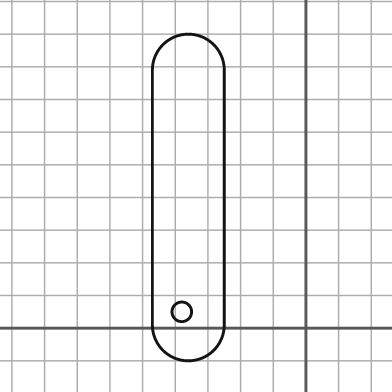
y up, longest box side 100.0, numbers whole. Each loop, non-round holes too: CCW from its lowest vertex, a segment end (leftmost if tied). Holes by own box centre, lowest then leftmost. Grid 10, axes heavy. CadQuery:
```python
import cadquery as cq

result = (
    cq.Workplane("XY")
    .moveTo(-47.0, 1.0)
    .threePointArc((-36.0, -10.0), (-25.0, 1.0))
    .lineTo(-25.0, 79.0)
    .threePointArc((-36.0, 90.0), (-47.0, 79.0))
    .close()
    .moveTo(-38.0, 5.0)
    .circle(3.0)
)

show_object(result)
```